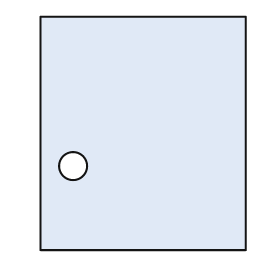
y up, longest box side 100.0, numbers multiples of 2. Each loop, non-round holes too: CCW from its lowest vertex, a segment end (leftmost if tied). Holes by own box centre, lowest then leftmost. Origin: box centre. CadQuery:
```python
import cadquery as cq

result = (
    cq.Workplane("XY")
    .moveTo(-44.0, -50.0)
    .lineTo(44.0, -50.0)
    .lineTo(44.0, 50.0)
    .lineTo(-44.0, 50.0)
    .close()
    .moveTo(-30.0, -14.0)
    .circle(6.0)
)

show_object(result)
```